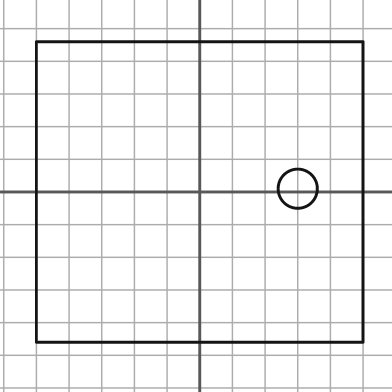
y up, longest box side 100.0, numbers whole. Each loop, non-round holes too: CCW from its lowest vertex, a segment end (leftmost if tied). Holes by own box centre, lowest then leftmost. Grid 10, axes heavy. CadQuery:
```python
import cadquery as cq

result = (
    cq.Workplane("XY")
    .moveTo(-50.0, -46.0)
    .lineTo(50.0, -46.0)
    .lineTo(50.0, 46.0)
    .lineTo(-50.0, 46.0)
    .close()
    .moveTo(30.0, 1.0)
    .circle(6.0)
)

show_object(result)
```